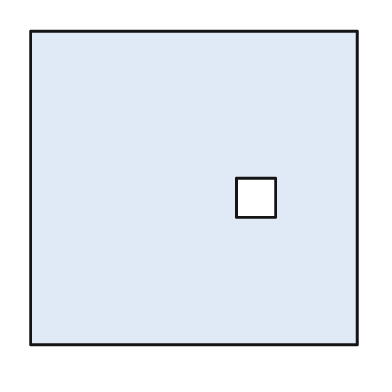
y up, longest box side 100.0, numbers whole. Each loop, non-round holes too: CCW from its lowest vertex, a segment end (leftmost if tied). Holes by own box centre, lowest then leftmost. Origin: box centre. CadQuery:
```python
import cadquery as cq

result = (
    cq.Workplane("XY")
    .moveTo(-50.0, -48.0)
    .lineTo(50.0, -48.0)
    .lineTo(50.0, 48.0)
    .lineTo(-50.0, 48.0)
    .close()
    .moveTo(13.0, -9.0)
    .lineTo(25.0, -9.0)
    .lineTo(25.0, 3.0)
    .lineTo(13.0, 3.0)
    .close()
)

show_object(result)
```